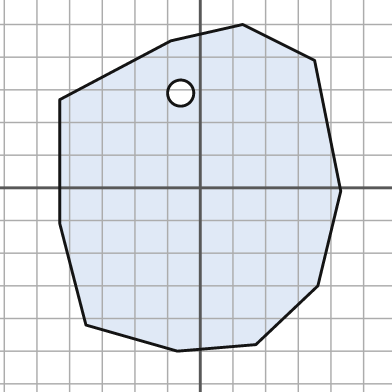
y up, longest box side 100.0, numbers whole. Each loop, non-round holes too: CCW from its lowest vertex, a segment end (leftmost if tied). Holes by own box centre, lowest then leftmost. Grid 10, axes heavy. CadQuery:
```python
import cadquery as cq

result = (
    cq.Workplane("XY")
    .moveTo(-7.0, -50.0)
    .lineTo(17.0, -48.0)
    .lineTo(36.0, -30.0)
    .lineTo(43.0, -1.0)
    .lineTo(35.0, 39.0)
    .lineTo(13.0, 50.0)
    .lineTo(-9.0, 45.0)
    .lineTo(-43.0, 27.0)
    .lineTo(-43.0, -11.0)
    .lineTo(-35.0, -42.0)
    .close()
    .moveTo(-6.0, 29.0)
    .circle(4.0)
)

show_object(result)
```